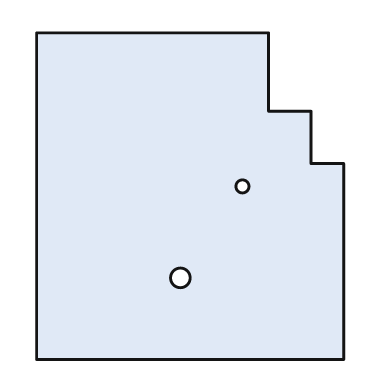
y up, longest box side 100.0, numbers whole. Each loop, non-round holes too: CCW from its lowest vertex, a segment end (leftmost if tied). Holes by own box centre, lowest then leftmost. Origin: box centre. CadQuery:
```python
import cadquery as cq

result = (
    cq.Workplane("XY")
    .moveTo(-47.0, -50.0)
    .lineTo(47.0, -50.0)
    .lineTo(47.0, 10.0)
    .lineTo(37.0, 10.0)
    .lineTo(37.0, 26.0)
    .lineTo(24.0, 26.0)
    .lineTo(24.0, 50.0)
    .lineTo(-47.0, 50.0)
    .close()
    .moveTo(-3.0, -25.0)
    .circle(3.0)
    .moveTo(16.0, 3.0)
    .circle(2.0)
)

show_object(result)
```